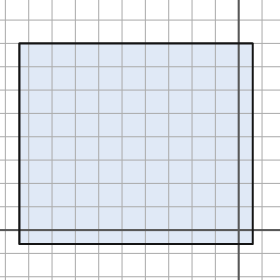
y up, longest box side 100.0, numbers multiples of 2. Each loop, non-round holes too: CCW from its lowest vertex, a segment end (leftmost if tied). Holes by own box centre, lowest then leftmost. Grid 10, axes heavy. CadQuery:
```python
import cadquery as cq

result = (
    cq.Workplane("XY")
    .moveTo(-94.0, -6.0)
    .lineTo(6.0, -6.0)
    .lineTo(6.0, 80.0)
    .lineTo(-94.0, 80.0)
    .close()
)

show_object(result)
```